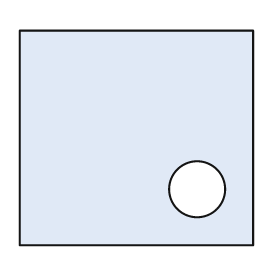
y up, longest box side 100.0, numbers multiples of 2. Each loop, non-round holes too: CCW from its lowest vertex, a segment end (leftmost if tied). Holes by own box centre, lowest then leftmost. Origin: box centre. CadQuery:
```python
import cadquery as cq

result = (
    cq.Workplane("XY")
    .moveTo(-50.0, -46.0)
    .lineTo(50.0, -46.0)
    .lineTo(50.0, 46.0)
    .lineTo(-50.0, 46.0)
    .close()
    .moveTo(26.0, -22.0)
    .circle(12.0)
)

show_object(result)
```